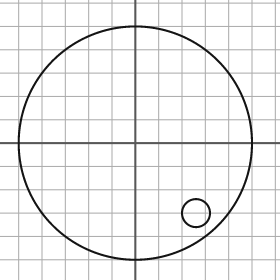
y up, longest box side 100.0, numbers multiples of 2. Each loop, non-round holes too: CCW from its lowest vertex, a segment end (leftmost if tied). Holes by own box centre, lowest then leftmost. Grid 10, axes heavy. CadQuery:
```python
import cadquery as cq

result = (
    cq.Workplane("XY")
    .moveTo(0.0, 0.0)
    .circle(50.0)
    .moveTo(26.0, -30.0)
    .circle(6.0)
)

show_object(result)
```